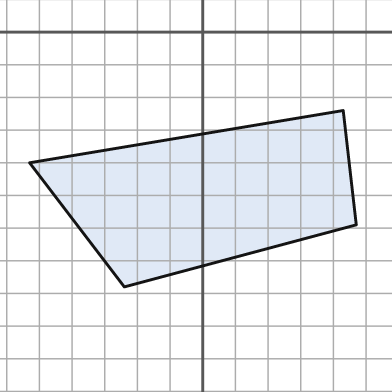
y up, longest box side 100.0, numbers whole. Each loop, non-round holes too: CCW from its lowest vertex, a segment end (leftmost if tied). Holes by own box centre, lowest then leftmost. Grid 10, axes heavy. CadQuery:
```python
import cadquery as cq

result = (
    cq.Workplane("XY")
    .moveTo(-24.0, -78.0)
    .lineTo(47.0, -59.0)
    .lineTo(43.0, -24.0)
    .lineTo(-53.0, -40.0)
    .close()
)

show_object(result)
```